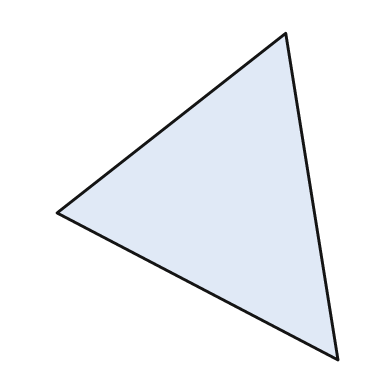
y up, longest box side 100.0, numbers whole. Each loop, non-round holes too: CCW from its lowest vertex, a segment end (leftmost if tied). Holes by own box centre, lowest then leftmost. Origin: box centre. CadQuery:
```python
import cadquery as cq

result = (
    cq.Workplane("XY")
    .moveTo(43.0, -50.0)
    .lineTo(27.0, 50.0)
    .lineTo(-43.0, -5.0)
    .close()
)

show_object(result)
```